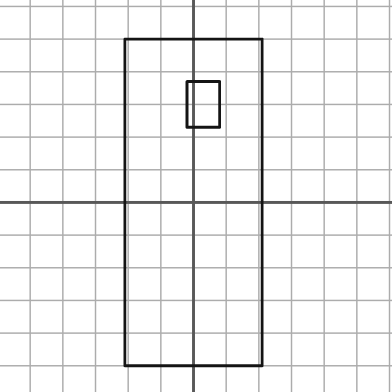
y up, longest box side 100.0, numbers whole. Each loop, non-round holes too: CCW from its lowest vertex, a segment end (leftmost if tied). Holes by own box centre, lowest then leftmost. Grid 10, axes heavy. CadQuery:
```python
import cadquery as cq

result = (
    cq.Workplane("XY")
    .moveTo(-21.0, -50.0)
    .lineTo(21.0, -50.0)
    .lineTo(21.0, 50.0)
    .lineTo(-21.0, 50.0)
    .close()
    .moveTo(-2.0, 23.0)
    .lineTo(8.0, 23.0)
    .lineTo(8.0, 37.0)
    .lineTo(-2.0, 37.0)
    .close()
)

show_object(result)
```